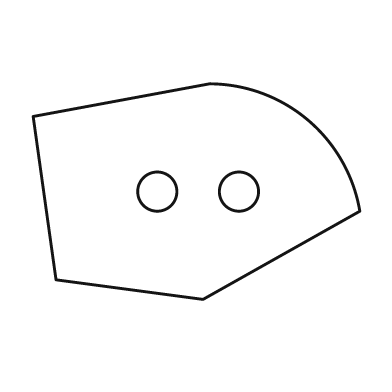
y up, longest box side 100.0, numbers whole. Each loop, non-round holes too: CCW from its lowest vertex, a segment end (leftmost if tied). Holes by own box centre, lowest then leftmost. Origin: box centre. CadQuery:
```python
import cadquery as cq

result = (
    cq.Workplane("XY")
    .moveTo(2.0, -33.0)
    .lineTo(50.0, -6.0)
    .threePointArc((34.0, 22.0), (4.0, 33.0))
    .lineTo(-50.0, 23.0)
    .lineTo(-43.0, -27.0)
    .close()
    .moveTo(-12.0, 0.0)
    .circle(6.0)
    .moveTo(13.0, 0.0)
    .circle(6.0)
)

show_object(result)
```